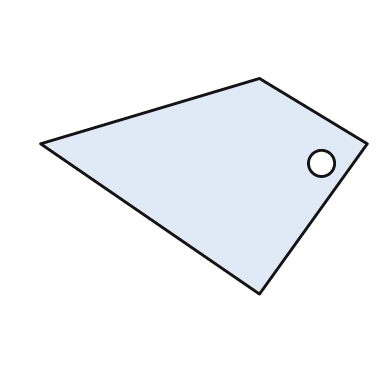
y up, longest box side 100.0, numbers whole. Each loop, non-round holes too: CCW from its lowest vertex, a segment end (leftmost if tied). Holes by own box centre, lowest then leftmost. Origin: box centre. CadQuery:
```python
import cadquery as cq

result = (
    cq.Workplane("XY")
    .moveTo(17.0, -33.0)
    .lineTo(50.0, 13.0)
    .lineTo(17.0, 33.0)
    .lineTo(-50.0, 13.0)
    .close()
    .moveTo(36.0, 7.0)
    .circle(4.0)
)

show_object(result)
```